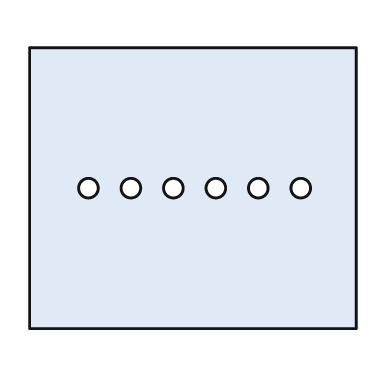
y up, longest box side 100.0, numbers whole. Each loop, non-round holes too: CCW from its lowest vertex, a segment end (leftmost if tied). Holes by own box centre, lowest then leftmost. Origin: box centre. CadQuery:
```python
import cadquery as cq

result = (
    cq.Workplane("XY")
    .moveTo(-50.0, -43.0)
    .lineTo(50.0, -43.0)
    .lineTo(50.0, 43.0)
    .lineTo(-50.0, 43.0)
    .close()
    .moveTo(-32.0, 0.0)
    .circle(3.0)
    .moveTo(-19.0, 0.0)
    .circle(3.0)
    .moveTo(-6.0, 0.0)
    .circle(3.0)
    .moveTo(7.0, 0.0)
    .circle(3.0)
    .moveTo(20.0, 0.0)
    .circle(3.0)
    .moveTo(33.0, 0.0)
    .circle(3.0)
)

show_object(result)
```